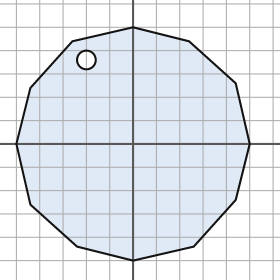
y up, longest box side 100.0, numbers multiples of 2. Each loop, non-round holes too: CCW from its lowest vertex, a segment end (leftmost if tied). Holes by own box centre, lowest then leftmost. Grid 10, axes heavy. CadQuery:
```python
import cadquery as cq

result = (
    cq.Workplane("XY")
    .moveTo(0.0, -50.0)
    .lineTo(26.0, -44.0)
    .lineTo(44.0, -24.0)
    .lineTo(50.0, 0.0)
    .lineTo(44.0, 26.0)
    .lineTo(24.0, 44.0)
    .lineTo(0.0, 50.0)
    .lineTo(-26.0, 44.0)
    .lineTo(-44.0, 24.0)
    .lineTo(-50.0, 0.0)
    .lineTo(-44.0, -26.0)
    .lineTo(-24.0, -44.0)
    .close()
    .moveTo(-20.0, 36.0)
    .circle(4.0)
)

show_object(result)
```